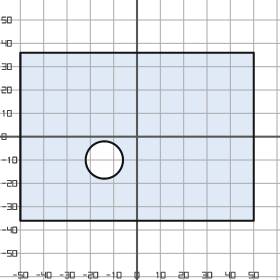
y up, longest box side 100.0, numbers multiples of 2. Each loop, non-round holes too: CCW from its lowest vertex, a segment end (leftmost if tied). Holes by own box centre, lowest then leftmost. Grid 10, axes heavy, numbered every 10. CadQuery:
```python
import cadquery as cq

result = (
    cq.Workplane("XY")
    .moveTo(-50.0, -36.0)
    .lineTo(50.0, -36.0)
    .lineTo(50.0, 36.0)
    .lineTo(-50.0, 36.0)
    .close()
    .moveTo(-14.0, -10.0)
    .circle(8.0)
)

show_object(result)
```